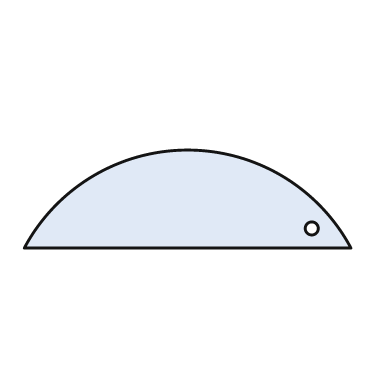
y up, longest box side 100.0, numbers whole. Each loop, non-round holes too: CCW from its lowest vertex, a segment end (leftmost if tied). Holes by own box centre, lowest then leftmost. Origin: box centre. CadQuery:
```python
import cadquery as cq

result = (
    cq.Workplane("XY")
    .moveTo(-50.0, -15.0)
    .lineTo(50.0, -15.0)
    .threePointArc((0.0, 15.0), (-50.0, -15.0))
    .close()
    .moveTo(38.0, -9.0)
    .circle(2.0)
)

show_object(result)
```